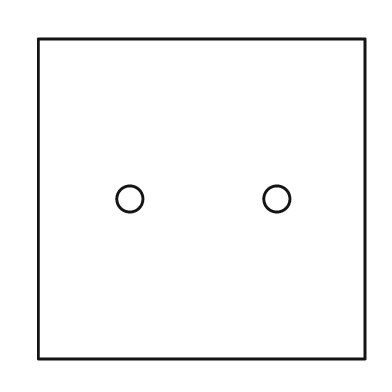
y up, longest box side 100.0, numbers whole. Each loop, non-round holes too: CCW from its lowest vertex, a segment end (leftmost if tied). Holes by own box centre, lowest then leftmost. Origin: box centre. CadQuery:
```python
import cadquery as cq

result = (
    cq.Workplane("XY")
    .moveTo(-50.0, -49.0)
    .lineTo(50.0, -49.0)
    .lineTo(50.0, 49.0)
    .lineTo(-50.0, 49.0)
    .close()
    .moveTo(-22.0, 0.0)
    .circle(4.0)
    .moveTo(23.0, 0.0)
    .circle(4.0)
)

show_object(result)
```